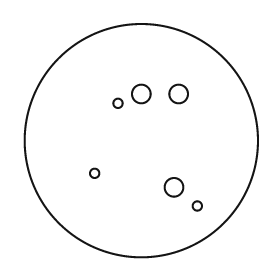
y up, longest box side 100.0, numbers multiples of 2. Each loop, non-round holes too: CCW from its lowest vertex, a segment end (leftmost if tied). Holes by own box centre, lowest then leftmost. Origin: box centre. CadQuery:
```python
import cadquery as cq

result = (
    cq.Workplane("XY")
    .moveTo(0.0, 0.0)
    .circle(50.0)
    .moveTo(24.0, -28.0)
    .circle(2.0)
    .moveTo(14.0, -20.0)
    .circle(4.0)
    .moveTo(-20.0, -14.0)
    .circle(2.0)
    .moveTo(-10.0, 16.0)
    .circle(2.0)
    .moveTo(0.0, 20.0)
    .circle(4.0)
    .moveTo(16.0, 20.0)
    .circle(4.0)
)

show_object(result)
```